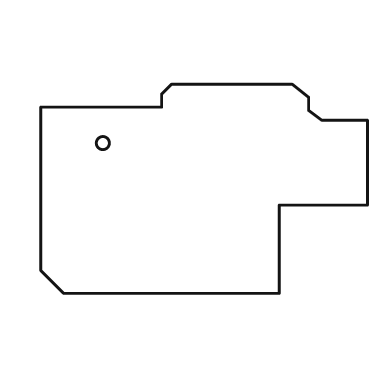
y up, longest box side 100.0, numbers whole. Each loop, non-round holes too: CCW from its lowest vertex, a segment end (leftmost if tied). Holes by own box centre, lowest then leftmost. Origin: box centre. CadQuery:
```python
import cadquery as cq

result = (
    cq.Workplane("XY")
    .moveTo(-43.0, -32.0)
    .lineTo(23.0, -32.0)
    .lineTo(23.0, -5.0)
    .lineTo(50.0, -5.0)
    .lineTo(50.0, 21.0)
    .lineTo(36.0, 21.0)
    .lineTo(32.0, 24.0)
    .lineTo(32.0, 28.0)
    .lineTo(27.0, 32.0)
    .lineTo(-10.0, 32.0)
    .lineTo(-13.0, 29.0)
    .lineTo(-13.0, 25.0)
    .lineTo(-50.0, 25.0)
    .lineTo(-50.0, -25.0)
    .close()
    .moveTo(-31.0, 14.0)
    .circle(2.0)
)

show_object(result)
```